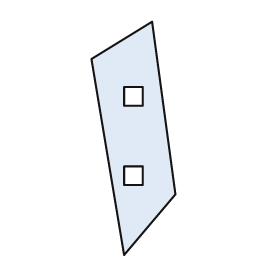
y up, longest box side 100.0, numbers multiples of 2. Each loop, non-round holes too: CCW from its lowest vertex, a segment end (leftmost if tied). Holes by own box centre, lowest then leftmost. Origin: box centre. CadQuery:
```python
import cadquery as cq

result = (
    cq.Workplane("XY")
    .moveTo(-4.0, -50.0)
    .lineTo(18.0, -24.0)
    .lineTo(8.0, 50.0)
    .lineTo(-18.0, 34.0)
    .close()
    .moveTo(-4.0, -20.0)
    .lineTo(4.0, -20.0)
    .lineTo(4.0, -12.0)
    .lineTo(-4.0, -12.0)
    .close()
    .moveTo(-4.0, 14.0)
    .lineTo(4.0, 14.0)
    .lineTo(4.0, 22.0)
    .lineTo(-4.0, 22.0)
    .close()
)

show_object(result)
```